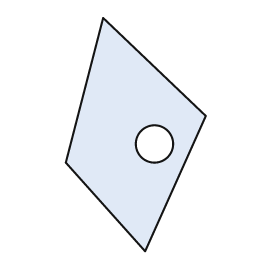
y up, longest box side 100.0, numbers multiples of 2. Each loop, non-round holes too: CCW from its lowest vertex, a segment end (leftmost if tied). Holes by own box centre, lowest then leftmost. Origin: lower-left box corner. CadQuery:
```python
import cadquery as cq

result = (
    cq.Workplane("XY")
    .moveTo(34.0, 0.0)
    .lineTo(60.0, 58.0)
    .lineTo(16.0, 100.0)
    .lineTo(0.0, 38.0)
    .close()
    .moveTo(38.0, 46.0)
    .circle(8.0)
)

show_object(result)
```